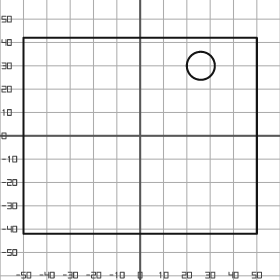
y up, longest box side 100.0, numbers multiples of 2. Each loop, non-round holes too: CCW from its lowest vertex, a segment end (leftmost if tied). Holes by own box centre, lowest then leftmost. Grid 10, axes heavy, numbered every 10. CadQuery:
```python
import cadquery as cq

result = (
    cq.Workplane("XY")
    .moveTo(-50.0, -42.0)
    .lineTo(50.0, -42.0)
    .lineTo(50.0, 42.0)
    .lineTo(-50.0, 42.0)
    .close()
    .moveTo(26.0, 30.0)
    .circle(6.0)
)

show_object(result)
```